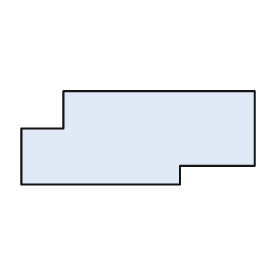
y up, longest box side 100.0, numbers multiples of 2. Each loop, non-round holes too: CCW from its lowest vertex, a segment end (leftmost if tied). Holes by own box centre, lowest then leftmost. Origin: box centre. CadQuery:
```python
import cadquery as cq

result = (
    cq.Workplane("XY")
    .moveTo(-50.0, -20.0)
    .lineTo(18.0, -20.0)
    .lineTo(18.0, -12.0)
    .lineTo(50.0, -12.0)
    .lineTo(50.0, 20.0)
    .lineTo(-32.0, 20.0)
    .lineTo(-32.0, 4.0)
    .lineTo(-50.0, 4.0)
    .close()
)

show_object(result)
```